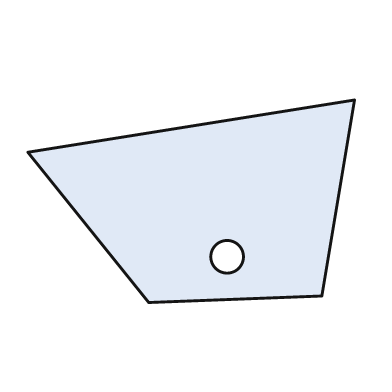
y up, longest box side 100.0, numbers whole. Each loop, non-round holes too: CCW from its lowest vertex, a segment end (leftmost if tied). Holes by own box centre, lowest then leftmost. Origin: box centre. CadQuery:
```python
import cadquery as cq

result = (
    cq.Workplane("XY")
    .moveTo(-13.0, -31.0)
    .lineTo(40.0, -29.0)
    .lineTo(50.0, 31.0)
    .lineTo(-50.0, 15.0)
    .close()
    .moveTo(11.0, -17.0)
    .circle(5.0)
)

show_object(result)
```